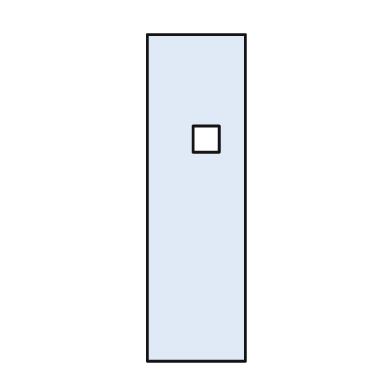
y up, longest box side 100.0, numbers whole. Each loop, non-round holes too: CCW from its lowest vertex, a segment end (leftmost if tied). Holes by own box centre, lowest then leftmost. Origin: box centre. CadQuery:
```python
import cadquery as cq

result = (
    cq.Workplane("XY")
    .moveTo(-15.0, -50.0)
    .lineTo(15.0, -50.0)
    .lineTo(15.0, 50.0)
    .lineTo(-15.0, 50.0)
    .close()
    .moveTo(-1.0, 14.0)
    .lineTo(7.0, 14.0)
    .lineTo(7.0, 22.0)
    .lineTo(-1.0, 22.0)
    .close()
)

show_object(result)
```